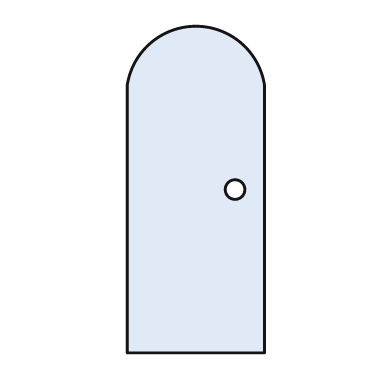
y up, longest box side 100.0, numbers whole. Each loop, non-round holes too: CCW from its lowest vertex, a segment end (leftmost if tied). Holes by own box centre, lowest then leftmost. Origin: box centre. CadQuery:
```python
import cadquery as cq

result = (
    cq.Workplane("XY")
    .moveTo(-21.0, -50.0)
    .lineTo(21.0, -50.0)
    .lineTo(21.0, 32.0)
    .threePointArc((0.0, 50.0), (-21.0, 32.0))
    .close()
    .moveTo(12.0, 0.0)
    .circle(3.0)
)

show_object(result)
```